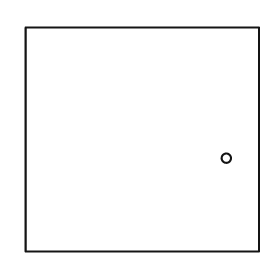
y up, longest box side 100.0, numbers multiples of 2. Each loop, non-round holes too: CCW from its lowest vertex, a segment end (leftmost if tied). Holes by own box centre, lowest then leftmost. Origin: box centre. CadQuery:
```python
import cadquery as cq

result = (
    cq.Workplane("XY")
    .moveTo(-50.0, -48.0)
    .lineTo(50.0, -48.0)
    .lineTo(50.0, 48.0)
    .lineTo(-50.0, 48.0)
    .close()
    .moveTo(36.0, -8.0)
    .circle(2.0)
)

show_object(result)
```